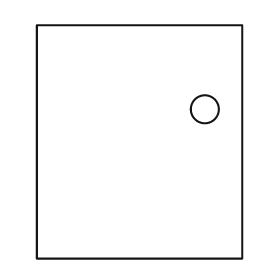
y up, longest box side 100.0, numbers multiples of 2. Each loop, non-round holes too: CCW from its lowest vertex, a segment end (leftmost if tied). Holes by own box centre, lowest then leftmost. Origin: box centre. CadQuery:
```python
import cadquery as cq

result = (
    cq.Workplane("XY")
    .moveTo(-44.0, -50.0)
    .lineTo(44.0, -50.0)
    .lineTo(44.0, 50.0)
    .lineTo(-44.0, 50.0)
    .close()
    .moveTo(28.0, 14.0)
    .circle(6.0)
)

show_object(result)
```